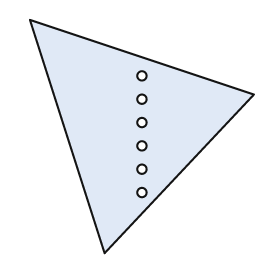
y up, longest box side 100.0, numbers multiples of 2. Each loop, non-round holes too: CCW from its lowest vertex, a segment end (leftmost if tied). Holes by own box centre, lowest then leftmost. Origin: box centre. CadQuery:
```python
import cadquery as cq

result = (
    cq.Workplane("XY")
    .moveTo(-16.0, -50.0)
    .lineTo(48.0, 18.0)
    .lineTo(-48.0, 50.0)
    .close()
    .moveTo(0.0, -24.0)
    .circle(2.0)
    .moveTo(0.0, -14.0)
    .circle(2.0)
    .moveTo(0.0, -4.0)
    .circle(2.0)
    .moveTo(0.0, 6.0)
    .circle(2.0)
    .moveTo(0.0, 16.0)
    .circle(2.0)
    .moveTo(0.0, 26.0)
    .circle(2.0)
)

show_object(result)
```